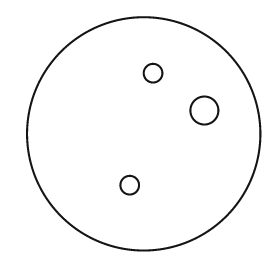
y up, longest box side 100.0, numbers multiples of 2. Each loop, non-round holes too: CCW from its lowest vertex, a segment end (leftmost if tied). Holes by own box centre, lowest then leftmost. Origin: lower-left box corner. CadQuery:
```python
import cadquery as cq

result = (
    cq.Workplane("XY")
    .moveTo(50.0, 50.0)
    .circle(50.0)
    .moveTo(44.0, 28.0)
    .circle(4.0)
    .moveTo(76.0, 60.0)
    .circle(6.0)
    .moveTo(54.0, 76.0)
    .circle(4.0)
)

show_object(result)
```